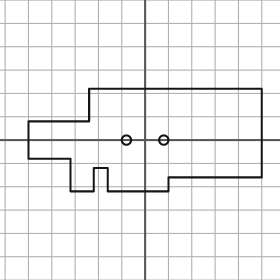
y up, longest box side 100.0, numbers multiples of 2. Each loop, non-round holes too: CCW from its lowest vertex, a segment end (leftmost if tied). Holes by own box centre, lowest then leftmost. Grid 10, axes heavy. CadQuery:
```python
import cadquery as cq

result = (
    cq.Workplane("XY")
    .moveTo(-32.0, -22.0)
    .lineTo(-22.0, -22.0)
    .lineTo(-22.0, -12.0)
    .lineTo(-16.0, -12.0)
    .lineTo(-16.0, -22.0)
    .lineTo(10.0, -22.0)
    .lineTo(10.0, -16.0)
    .lineTo(50.0, -16.0)
    .lineTo(50.0, 22.0)
    .lineTo(-24.0, 22.0)
    .lineTo(-24.0, 8.0)
    .lineTo(-50.0, 8.0)
    .lineTo(-50.0, -8.0)
    .lineTo(-32.0, -8.0)
    .close()
    .moveTo(-8.0, 0.0)
    .circle(2.0)
    .moveTo(8.0, 0.0)
    .circle(2.0)
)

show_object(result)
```